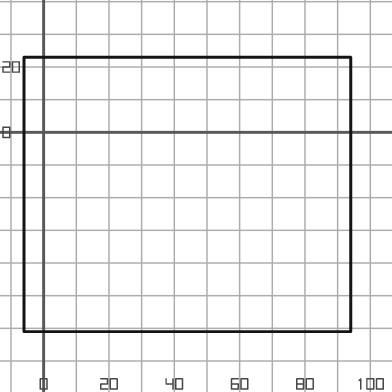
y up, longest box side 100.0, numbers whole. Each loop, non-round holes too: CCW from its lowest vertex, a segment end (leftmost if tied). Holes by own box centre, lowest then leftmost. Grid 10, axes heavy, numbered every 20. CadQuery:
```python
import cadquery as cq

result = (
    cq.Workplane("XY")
    .moveTo(-6.0, -61.0)
    .lineTo(94.0, -61.0)
    .lineTo(94.0, 23.0)
    .lineTo(-6.0, 23.0)
    .close()
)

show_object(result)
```